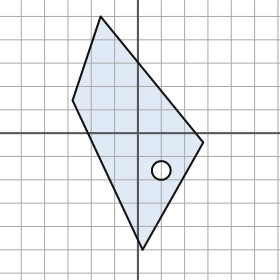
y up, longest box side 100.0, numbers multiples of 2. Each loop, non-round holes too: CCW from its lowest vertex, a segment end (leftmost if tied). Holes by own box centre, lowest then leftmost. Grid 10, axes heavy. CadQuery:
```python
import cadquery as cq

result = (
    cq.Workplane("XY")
    .moveTo(2.0, -50.0)
    .lineTo(28.0, -4.0)
    .lineTo(-16.0, 50.0)
    .lineTo(-28.0, 14.0)
    .close()
    .moveTo(10.0, -16.0)
    .circle(4.0)
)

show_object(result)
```